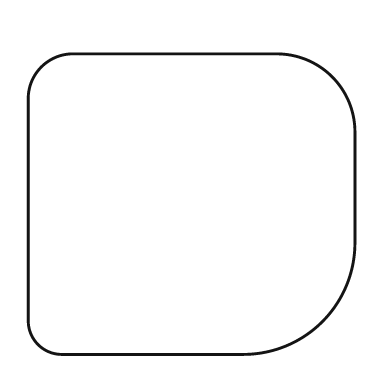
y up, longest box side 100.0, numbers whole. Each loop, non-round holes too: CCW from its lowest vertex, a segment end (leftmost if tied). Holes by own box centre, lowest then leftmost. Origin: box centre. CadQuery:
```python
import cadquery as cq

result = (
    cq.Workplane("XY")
    .moveTo(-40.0, -46.0)
    .lineTo(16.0, -46.0)
    .threePointArc((40.0, -36.0), (50.0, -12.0))
    .lineTo(50.0, 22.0)
    .threePointArc((43.0, 39.0), (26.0, 46.0))
    .lineTo(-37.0, 46.0)
    .threePointArc((-46.0, 42.0), (-50.0, 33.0))
    .lineTo(-50.0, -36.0)
    .threePointArc((-47.0, -43.0), (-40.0, -46.0))
    .close()
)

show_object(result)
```